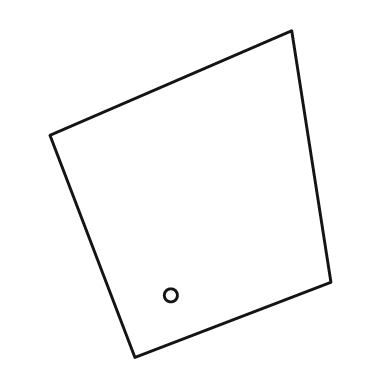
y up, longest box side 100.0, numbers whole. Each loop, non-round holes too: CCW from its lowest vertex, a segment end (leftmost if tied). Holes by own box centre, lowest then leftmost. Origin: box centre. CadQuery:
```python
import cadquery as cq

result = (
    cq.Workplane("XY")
    .moveTo(-17.0, -50.0)
    .lineTo(43.0, -27.0)
    .lineTo(31.0, 50.0)
    .lineTo(-43.0, 18.0)
    .close()
    .moveTo(-6.0, -31.0)
    .circle(2.0)
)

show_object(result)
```